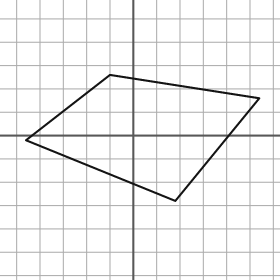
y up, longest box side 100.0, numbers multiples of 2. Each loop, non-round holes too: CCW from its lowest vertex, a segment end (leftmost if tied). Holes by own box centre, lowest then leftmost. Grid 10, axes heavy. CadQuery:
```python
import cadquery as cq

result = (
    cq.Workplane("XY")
    .moveTo(18.0, -28.0)
    .lineTo(54.0, 16.0)
    .lineTo(-10.0, 26.0)
    .lineTo(-46.0, -2.0)
    .close()
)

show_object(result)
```